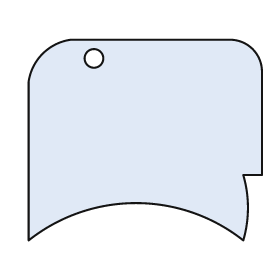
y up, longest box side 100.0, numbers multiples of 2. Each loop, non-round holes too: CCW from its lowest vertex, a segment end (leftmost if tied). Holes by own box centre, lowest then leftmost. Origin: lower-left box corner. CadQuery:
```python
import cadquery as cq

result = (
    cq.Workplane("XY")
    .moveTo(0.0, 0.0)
    .threePointArc((46.0, 16.0), (92.0, 0.0))
    .threePointArc((94.0, 14.0), (92.0, 28.0))
    .lineTo(100.0, 28.0)
    .lineTo(100.0, 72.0)
    .threePointArc((96.0, 82.0), (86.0, 86.0))
    .lineTo(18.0, 86.0)
    .threePointArc((6.0, 80.0), (0.0, 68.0))
    .close()
    .moveTo(28.0, 78.0)
    .circle(4.0)
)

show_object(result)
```